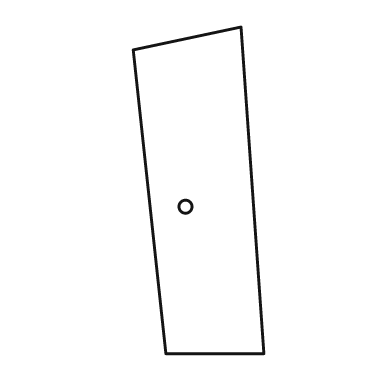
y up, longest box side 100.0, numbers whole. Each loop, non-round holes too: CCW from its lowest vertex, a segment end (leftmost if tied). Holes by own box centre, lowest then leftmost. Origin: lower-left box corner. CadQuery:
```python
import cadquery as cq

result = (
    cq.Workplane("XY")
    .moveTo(10.0, 0.0)
    .lineTo(40.0, 0.0)
    .lineTo(33.0, 100.0)
    .lineTo(0.0, 93.0)
    .close()
    .moveTo(16.0, 45.0)
    .circle(2.0)
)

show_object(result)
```